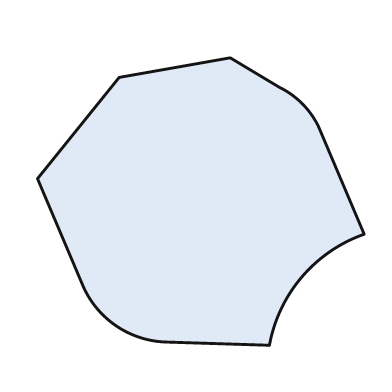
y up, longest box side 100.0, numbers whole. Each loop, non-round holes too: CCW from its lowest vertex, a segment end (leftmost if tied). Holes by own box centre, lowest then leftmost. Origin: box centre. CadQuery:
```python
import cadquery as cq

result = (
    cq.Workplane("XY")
    .moveTo(21.0, -44.0)
    .threePointArc((31.0, -23.0), (50.0, -10.0))
    .lineTo(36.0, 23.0)
    .threePointArc((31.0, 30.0), (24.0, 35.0))
    .lineTo(9.0, 44.0)
    .lineTo(-25.0, 38.0)
    .lineTo(-50.0, 7.0)
    .lineTo(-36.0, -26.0)
    .threePointArc((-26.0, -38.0), (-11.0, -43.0))
    .close()
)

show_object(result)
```